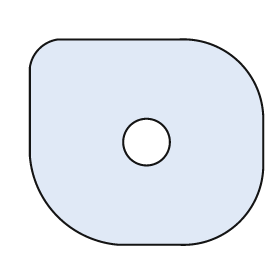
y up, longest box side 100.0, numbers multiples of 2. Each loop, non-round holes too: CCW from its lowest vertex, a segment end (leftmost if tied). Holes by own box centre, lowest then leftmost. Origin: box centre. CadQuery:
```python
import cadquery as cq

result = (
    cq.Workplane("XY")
    .moveTo(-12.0, -44.0)
    .lineTo(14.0, -44.0)
    .threePointArc((40.0, -34.0), (50.0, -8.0))
    .lineTo(50.0, 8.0)
    .threePointArc((40.0, 34.0), (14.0, 44.0))
    .lineTo(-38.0, 44.0)
    .threePointArc((-46.0, 40.0), (-50.0, 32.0))
    .lineTo(-50.0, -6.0)
    .threePointArc((-38.0, -32.0), (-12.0, -44.0))
    .close()
    .moveTo(0.0, 0.0)
    .circle(10.0)
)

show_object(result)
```